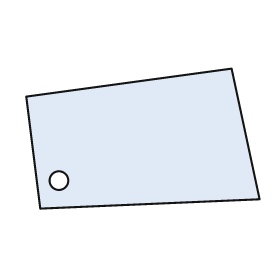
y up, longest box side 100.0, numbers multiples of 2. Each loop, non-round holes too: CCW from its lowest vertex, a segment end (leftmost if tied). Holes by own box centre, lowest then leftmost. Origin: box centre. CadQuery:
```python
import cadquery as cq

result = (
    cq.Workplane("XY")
    .moveTo(-44.0, -30.0)
    .lineTo(50.0, -26.0)
    .lineTo(38.0, 30.0)
    .lineTo(-50.0, 18.0)
    .close()
    .moveTo(-36.0, -18.0)
    .circle(4.0)
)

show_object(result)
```